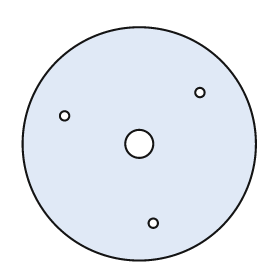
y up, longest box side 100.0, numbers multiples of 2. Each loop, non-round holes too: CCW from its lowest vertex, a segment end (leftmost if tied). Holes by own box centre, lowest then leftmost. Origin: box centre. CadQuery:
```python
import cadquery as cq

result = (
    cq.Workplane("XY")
    .moveTo(0.0, 0.0)
    .circle(50.0)
    .moveTo(6.0, -34.0)
    .circle(2.0)
    .moveTo(0.0, 0.0)
    .circle(6.0)
    .moveTo(-32.0, 12.0)
    .circle(2.0)
    .moveTo(26.0, 22.0)
    .circle(2.0)
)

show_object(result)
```